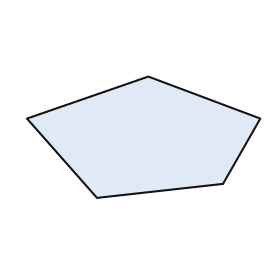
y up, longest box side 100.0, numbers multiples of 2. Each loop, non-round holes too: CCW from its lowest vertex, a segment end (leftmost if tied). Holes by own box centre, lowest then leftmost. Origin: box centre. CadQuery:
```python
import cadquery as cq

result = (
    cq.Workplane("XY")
    .moveTo(-20.0, -26.0)
    .lineTo(34.0, -20.0)
    .lineTo(50.0, 8.0)
    .lineTo(2.0, 26.0)
    .lineTo(-50.0, 8.0)
    .close()
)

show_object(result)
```